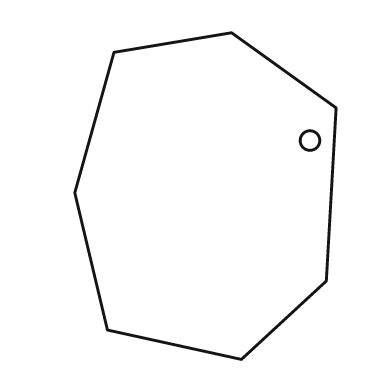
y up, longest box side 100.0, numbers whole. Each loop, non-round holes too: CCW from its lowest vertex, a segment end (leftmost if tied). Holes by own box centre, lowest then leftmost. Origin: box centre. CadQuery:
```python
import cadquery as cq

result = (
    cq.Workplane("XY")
    .moveTo(11.0, -50.0)
    .lineTo(37.0, -26.0)
    .lineTo(40.0, 27.0)
    .lineTo(8.0, 50.0)
    .lineTo(-28.0, 44.0)
    .lineTo(-40.0, 1.0)
    .lineTo(-30.0, -41.0)
    .close()
    .moveTo(32.0, 17.0)
    .circle(3.0)
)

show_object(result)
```